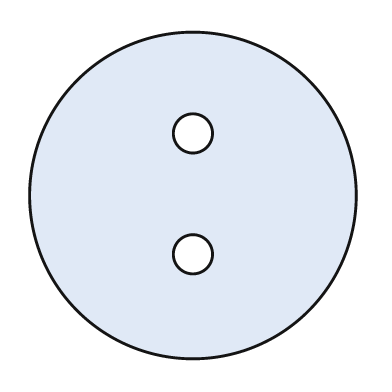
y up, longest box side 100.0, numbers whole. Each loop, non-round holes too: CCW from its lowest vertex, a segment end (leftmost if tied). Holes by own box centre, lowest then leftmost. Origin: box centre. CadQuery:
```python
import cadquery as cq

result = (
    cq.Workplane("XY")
    .moveTo(0.0, 0.0)
    .circle(50.0)
    .moveTo(0.0, -18.0)
    .circle(6.0)
    .moveTo(0.0, 19.0)
    .circle(6.0)
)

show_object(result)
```